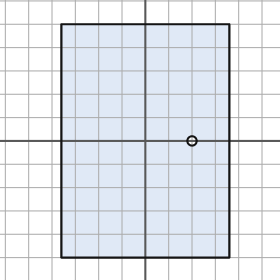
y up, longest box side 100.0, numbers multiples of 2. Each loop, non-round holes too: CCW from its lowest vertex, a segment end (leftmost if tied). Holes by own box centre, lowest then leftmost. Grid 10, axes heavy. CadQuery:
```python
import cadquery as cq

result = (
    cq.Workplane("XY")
    .moveTo(-36.0, -50.0)
    .lineTo(36.0, -50.0)
    .lineTo(36.0, 50.0)
    .lineTo(-36.0, 50.0)
    .close()
    .moveTo(20.0, 0.0)
    .circle(2.0)
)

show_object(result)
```